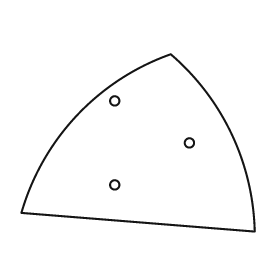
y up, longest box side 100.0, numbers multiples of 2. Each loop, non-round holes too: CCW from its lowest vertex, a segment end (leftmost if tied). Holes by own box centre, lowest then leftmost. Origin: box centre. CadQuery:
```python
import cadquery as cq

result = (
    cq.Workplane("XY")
    .moveTo(50.0, -38.0)
    .threePointArc((40.0, 4.0), (14.0, 38.0))
    .threePointArc((-26.0, 12.0), (-50.0, -30.0))
    .close()
    .moveTo(-10.0, -18.0)
    .circle(2.0)
    .moveTo(22.0, 0.0)
    .circle(2.0)
    .moveTo(-10.0, 18.0)
    .circle(2.0)
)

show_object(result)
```